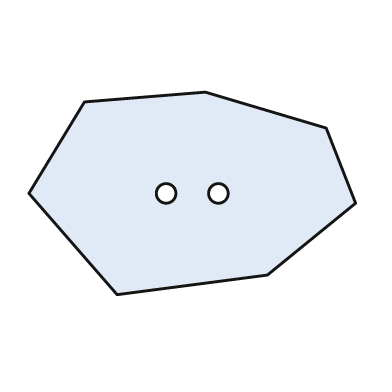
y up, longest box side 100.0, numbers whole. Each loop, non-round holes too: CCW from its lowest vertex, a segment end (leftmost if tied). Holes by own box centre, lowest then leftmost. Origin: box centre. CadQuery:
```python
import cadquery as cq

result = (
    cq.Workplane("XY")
    .moveTo(-23.0, -31.0)
    .lineTo(23.0, -25.0)
    .lineTo(50.0, -3.0)
    .lineTo(41.0, 20.0)
    .lineTo(4.0, 31.0)
    .lineTo(-33.0, 28.0)
    .lineTo(-50.0, 0.0)
    .close()
    .moveTo(-8.0, 0.0)
    .circle(3.0)
    .moveTo(8.0, 0.0)
    .circle(3.0)
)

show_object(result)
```